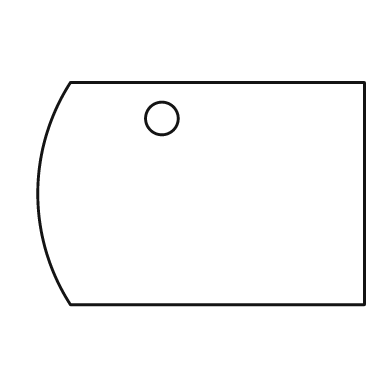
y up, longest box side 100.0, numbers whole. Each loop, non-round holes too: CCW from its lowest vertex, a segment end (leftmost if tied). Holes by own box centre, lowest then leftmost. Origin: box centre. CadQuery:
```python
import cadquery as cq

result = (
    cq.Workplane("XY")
    .moveTo(-40.0, -34.0)
    .lineTo(50.0, -34.0)
    .lineTo(50.0, 34.0)
    .lineTo(-40.0, 34.0)
    .threePointArc((-50.0, 0.0), (-40.0, -34.0))
    .close()
    .moveTo(-12.0, 23.0)
    .circle(5.0)
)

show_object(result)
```